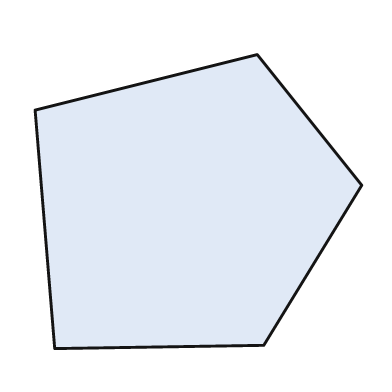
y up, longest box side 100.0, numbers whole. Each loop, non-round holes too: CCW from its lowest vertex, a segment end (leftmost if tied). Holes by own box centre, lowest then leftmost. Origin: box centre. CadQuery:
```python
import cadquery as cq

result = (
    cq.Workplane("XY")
    .moveTo(-44.0, -45.0)
    .lineTo(20.0, -44.0)
    .lineTo(50.0, 5.0)
    .lineTo(18.0, 45.0)
    .lineTo(-50.0, 28.0)
    .close()
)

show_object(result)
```